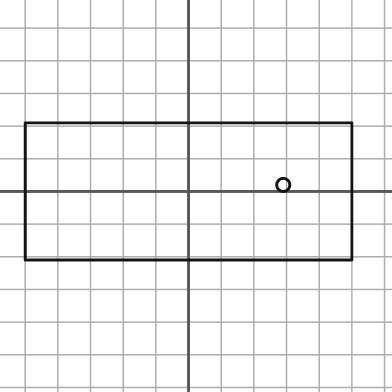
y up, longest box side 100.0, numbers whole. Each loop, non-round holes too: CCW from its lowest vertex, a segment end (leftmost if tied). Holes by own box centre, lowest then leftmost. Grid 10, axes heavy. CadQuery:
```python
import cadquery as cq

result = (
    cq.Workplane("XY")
    .moveTo(-50.0, -21.0)
    .lineTo(50.0, -21.0)
    .lineTo(50.0, 21.0)
    .lineTo(-50.0, 21.0)
    .close()
    .moveTo(29.0, 2.0)
    .circle(2.0)
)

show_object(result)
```